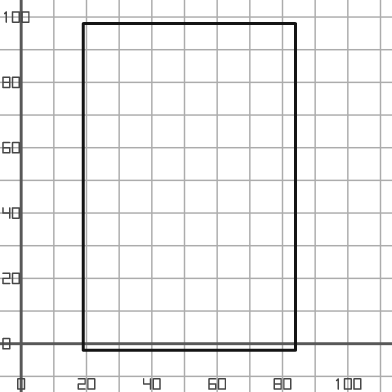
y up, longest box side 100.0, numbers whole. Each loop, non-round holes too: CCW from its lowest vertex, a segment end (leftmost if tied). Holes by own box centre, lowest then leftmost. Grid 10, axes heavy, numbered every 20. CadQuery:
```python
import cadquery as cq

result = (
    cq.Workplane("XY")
    .moveTo(19.0, -2.0)
    .lineTo(84.0, -2.0)
    .lineTo(84.0, 98.0)
    .lineTo(19.0, 98.0)
    .close()
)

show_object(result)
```